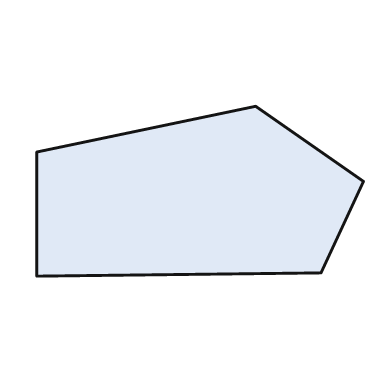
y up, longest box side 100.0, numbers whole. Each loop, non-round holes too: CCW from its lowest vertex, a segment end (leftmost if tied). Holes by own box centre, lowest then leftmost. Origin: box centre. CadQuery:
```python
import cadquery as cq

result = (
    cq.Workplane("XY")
    .moveTo(-50.0, -26.0)
    .lineTo(37.0, -25.0)
    .lineTo(50.0, 3.0)
    .lineTo(17.0, 26.0)
    .lineTo(-50.0, 12.0)
    .close()
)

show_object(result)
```